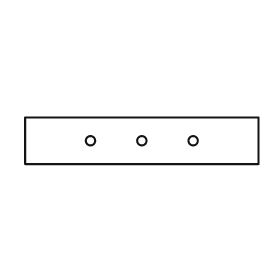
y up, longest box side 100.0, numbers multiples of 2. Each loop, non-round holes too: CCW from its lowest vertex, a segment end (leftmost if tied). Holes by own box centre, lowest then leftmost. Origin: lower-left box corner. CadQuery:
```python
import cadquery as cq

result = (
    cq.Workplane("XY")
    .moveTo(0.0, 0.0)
    .lineTo(100.0, 0.0)
    .lineTo(100.0, 20.0)
    .lineTo(0.0, 20.0)
    .close()
    .moveTo(28.0, 10.0)
    .circle(2.0)
    .moveTo(50.0, 10.0)
    .circle(2.0)
    .moveTo(72.0, 10.0)
    .circle(2.0)
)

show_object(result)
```